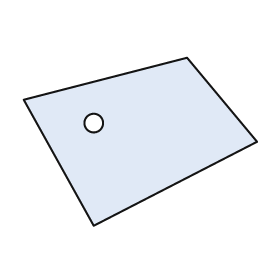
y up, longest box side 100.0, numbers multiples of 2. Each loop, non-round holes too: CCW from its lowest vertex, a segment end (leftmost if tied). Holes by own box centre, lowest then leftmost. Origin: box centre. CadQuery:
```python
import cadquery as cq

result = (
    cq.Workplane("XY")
    .moveTo(-20.0, -36.0)
    .lineTo(50.0, 0.0)
    .lineTo(20.0, 36.0)
    .lineTo(-50.0, 18.0)
    .close()
    .moveTo(-20.0, 8.0)
    .circle(4.0)
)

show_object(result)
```